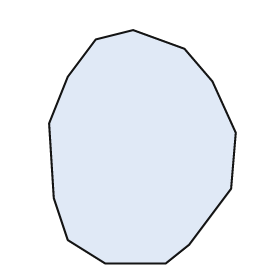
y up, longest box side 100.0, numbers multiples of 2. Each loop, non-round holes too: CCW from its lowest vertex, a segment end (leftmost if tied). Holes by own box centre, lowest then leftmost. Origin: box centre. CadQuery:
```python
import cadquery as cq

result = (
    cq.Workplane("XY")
    .moveTo(-16.0, -50.0)
    .lineTo(10.0, -50.0)
    .lineTo(20.0, -42.0)
    .lineTo(38.0, -18.0)
    .lineTo(40.0, 6.0)
    .lineTo(30.0, 28.0)
    .lineTo(18.0, 42.0)
    .lineTo(-4.0, 50.0)
    .lineTo(-20.0, 46.0)
    .lineTo(-32.0, 30.0)
    .lineTo(-40.0, 10.0)
    .lineTo(-38.0, -22.0)
    .lineTo(-32.0, -40.0)
    .close()
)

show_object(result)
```